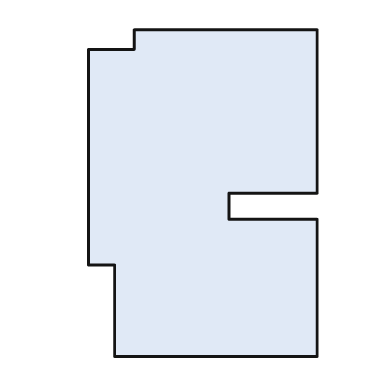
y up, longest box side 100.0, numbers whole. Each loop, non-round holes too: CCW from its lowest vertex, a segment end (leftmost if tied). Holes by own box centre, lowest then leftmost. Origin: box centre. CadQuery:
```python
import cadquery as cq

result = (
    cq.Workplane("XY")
    .moveTo(-27.0, -50.0)
    .lineTo(35.0, -50.0)
    .lineTo(35.0, -8.0)
    .lineTo(8.0, -8.0)
    .lineTo(8.0, 0.0)
    .lineTo(35.0, 0.0)
    .lineTo(35.0, 50.0)
    .lineTo(-21.0, 50.0)
    .lineTo(-21.0, 44.0)
    .lineTo(-35.0, 44.0)
    .lineTo(-35.0, -22.0)
    .lineTo(-27.0, -22.0)
    .close()
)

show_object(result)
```